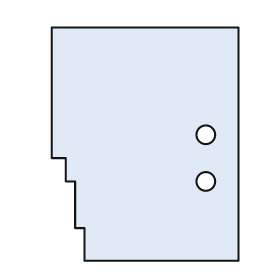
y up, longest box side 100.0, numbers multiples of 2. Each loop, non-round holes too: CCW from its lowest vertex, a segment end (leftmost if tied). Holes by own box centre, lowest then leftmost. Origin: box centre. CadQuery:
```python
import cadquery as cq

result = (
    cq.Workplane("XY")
    .moveTo(-26.0, -50.0)
    .lineTo(40.0, -50.0)
    .lineTo(40.0, 50.0)
    .lineTo(-40.0, 50.0)
    .lineTo(-40.0, -6.0)
    .lineTo(-34.0, -6.0)
    .lineTo(-34.0, -16.0)
    .lineTo(-30.0, -16.0)
    .lineTo(-30.0, -36.0)
    .lineTo(-26.0, -36.0)
    .close()
    .moveTo(26.0, -16.0)
    .circle(4.0)
    .moveTo(26.0, 4.0)
    .circle(4.0)
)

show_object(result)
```